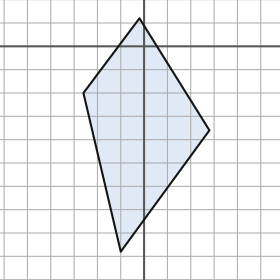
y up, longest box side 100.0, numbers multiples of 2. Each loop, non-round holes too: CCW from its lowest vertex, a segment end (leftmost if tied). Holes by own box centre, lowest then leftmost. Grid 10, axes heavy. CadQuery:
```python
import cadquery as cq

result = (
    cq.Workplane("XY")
    .moveTo(-10.0, -88.0)
    .lineTo(28.0, -36.0)
    .lineTo(-2.0, 12.0)
    .lineTo(-26.0, -20.0)
    .close()
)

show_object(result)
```